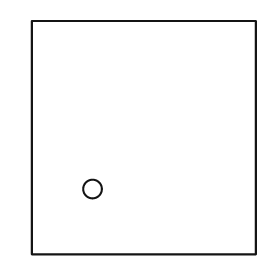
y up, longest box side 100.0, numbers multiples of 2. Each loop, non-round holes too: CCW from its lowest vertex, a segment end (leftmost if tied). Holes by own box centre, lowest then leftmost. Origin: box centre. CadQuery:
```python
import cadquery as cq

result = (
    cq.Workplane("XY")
    .moveTo(-48.0, -50.0)
    .lineTo(48.0, -50.0)
    .lineTo(48.0, 50.0)
    .lineTo(-48.0, 50.0)
    .close()
    .moveTo(-22.0, -22.0)
    .circle(4.0)
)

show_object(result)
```